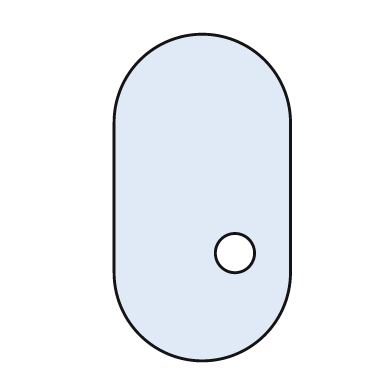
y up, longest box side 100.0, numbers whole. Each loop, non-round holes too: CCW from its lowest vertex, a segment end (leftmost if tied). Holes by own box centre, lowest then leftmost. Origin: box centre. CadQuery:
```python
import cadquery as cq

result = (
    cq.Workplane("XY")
    .moveTo(-27.0, -23.0)
    .threePointArc((0.0, -50.0), (27.0, -23.0))
    .lineTo(27.0, 23.0)
    .threePointArc((0.0, 50.0), (-27.0, 23.0))
    .close()
    .moveTo(10.0, -17.0)
    .circle(6.0)
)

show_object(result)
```